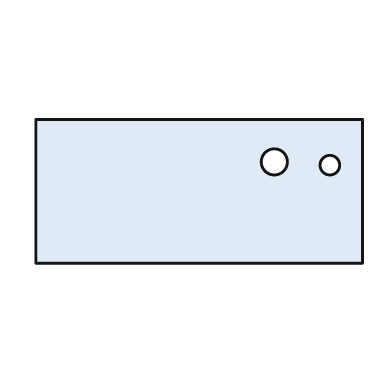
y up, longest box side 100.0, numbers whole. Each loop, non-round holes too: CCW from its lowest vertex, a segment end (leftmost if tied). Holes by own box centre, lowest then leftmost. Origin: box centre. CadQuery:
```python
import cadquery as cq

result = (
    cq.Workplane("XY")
    .moveTo(-50.0, -22.0)
    .lineTo(50.0, -22.0)
    .lineTo(50.0, 22.0)
    .lineTo(-50.0, 22.0)
    .close()
    .moveTo(40.0, 8.0)
    .circle(3.0)
    .moveTo(23.0, 9.0)
    .circle(4.0)
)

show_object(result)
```